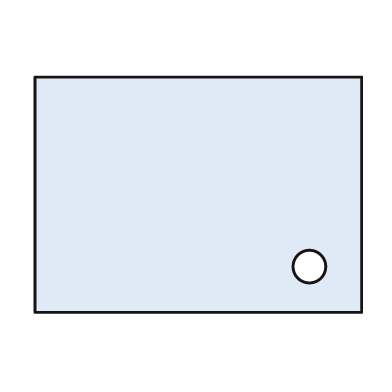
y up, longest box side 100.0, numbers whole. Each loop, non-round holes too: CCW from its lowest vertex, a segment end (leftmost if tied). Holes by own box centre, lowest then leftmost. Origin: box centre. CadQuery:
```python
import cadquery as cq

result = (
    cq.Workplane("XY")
    .moveTo(-50.0, -36.0)
    .lineTo(50.0, -36.0)
    .lineTo(50.0, 36.0)
    .lineTo(-50.0, 36.0)
    .close()
    .moveTo(34.0, -22.0)
    .circle(5.0)
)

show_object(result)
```